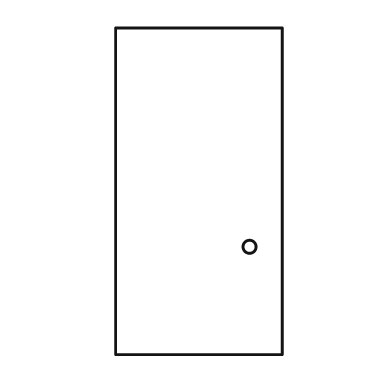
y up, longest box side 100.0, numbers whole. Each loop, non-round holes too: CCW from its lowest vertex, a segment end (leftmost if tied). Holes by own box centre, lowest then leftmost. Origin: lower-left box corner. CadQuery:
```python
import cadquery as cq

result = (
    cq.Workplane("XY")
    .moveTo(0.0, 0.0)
    .lineTo(51.0, 0.0)
    .lineTo(51.0, 100.0)
    .lineTo(0.0, 100.0)
    .close()
    .moveTo(41.0, 33.0)
    .circle(2.0)
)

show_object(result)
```